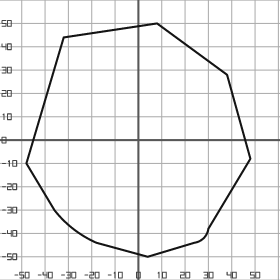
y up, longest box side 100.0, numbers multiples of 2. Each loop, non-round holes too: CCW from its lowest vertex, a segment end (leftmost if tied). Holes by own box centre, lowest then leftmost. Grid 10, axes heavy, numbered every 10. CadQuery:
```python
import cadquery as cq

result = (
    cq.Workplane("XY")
    .moveTo(4.0, -50.0)
    .lineTo(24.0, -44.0)
    .threePointArc((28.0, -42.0), (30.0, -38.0))
    .lineTo(48.0, -8.0)
    .lineTo(38.0, 28.0)
    .lineTo(8.0, 50.0)
    .lineTo(-32.0, 44.0)
    .lineTo(-48.0, -10.0)
    .lineTo(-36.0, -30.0)
    .threePointArc((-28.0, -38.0), (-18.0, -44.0))
    .close()
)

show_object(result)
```